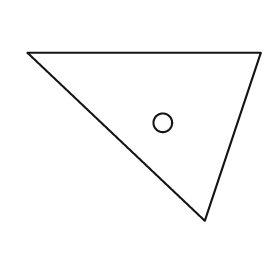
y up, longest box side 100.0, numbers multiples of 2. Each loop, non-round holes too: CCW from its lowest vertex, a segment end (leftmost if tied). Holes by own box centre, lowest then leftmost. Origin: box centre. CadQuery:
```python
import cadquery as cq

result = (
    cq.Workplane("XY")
    .moveTo(26.0, -36.0)
    .lineTo(50.0, 36.0)
    .lineTo(-50.0, 36.0)
    .close()
    .moveTo(8.0, 6.0)
    .circle(4.0)
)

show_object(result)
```